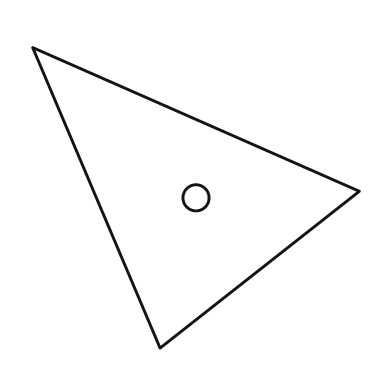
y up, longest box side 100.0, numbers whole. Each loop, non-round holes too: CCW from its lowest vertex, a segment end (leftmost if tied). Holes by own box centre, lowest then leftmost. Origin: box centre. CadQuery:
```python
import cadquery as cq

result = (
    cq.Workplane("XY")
    .moveTo(-11.0, -46.0)
    .lineTo(50.0, 2.0)
    .lineTo(-50.0, 46.0)
    .close()
    .moveTo(0.0, 0.0)
    .circle(4.0)
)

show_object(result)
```